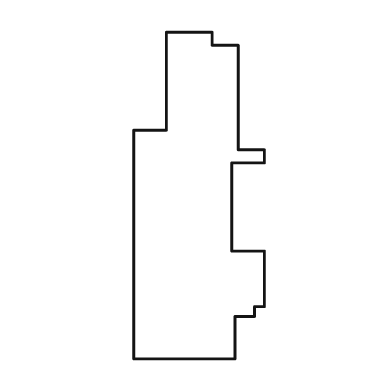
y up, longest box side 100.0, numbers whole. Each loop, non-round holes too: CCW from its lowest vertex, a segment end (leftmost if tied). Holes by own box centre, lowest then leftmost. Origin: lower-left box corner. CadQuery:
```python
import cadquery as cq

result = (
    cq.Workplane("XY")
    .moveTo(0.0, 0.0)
    .lineTo(31.0, 0.0)
    .lineTo(31.0, 13.0)
    .lineTo(37.0, 13.0)
    .lineTo(37.0, 16.0)
    .lineTo(40.0, 16.0)
    .lineTo(40.0, 33.0)
    .lineTo(30.0, 33.0)
    .lineTo(30.0, 60.0)
    .lineTo(40.0, 60.0)
    .lineTo(40.0, 64.0)
    .lineTo(32.0, 64.0)
    .lineTo(32.0, 96.0)
    .lineTo(24.0, 96.0)
    .lineTo(24.0, 100.0)
    .lineTo(10.0, 100.0)
    .lineTo(10.0, 70.0)
    .lineTo(0.0, 70.0)
    .close()
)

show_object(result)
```